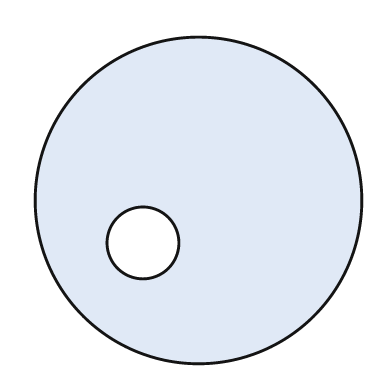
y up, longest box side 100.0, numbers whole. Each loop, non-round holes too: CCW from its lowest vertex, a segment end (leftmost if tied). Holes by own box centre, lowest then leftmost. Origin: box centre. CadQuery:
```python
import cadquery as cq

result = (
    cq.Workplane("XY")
    .moveTo(0.0, 0.0)
    .circle(50.0)
    .moveTo(-17.0, -13.0)
    .circle(11.0)
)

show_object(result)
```